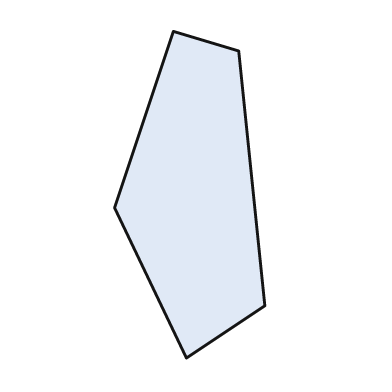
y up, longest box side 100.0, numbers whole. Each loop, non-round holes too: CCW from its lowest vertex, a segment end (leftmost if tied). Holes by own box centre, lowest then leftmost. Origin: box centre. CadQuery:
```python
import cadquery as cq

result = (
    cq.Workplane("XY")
    .moveTo(-1.0, -50.0)
    .lineTo(23.0, -34.0)
    .lineTo(15.0, 44.0)
    .lineTo(-5.0, 50.0)
    .lineTo(-23.0, -4.0)
    .close()
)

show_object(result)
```